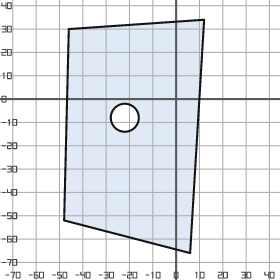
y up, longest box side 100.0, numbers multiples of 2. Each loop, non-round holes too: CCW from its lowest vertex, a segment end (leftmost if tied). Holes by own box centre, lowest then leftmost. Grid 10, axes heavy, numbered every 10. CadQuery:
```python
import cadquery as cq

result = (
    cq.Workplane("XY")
    .moveTo(6.0, -66.0)
    .lineTo(12.0, 34.0)
    .lineTo(-46.0, 30.0)
    .lineTo(-48.0, -52.0)
    .close()
    .moveTo(-22.0, -8.0)
    .circle(6.0)
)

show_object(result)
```